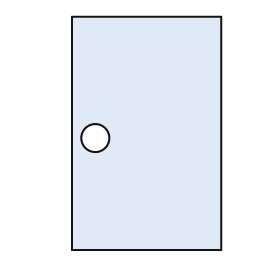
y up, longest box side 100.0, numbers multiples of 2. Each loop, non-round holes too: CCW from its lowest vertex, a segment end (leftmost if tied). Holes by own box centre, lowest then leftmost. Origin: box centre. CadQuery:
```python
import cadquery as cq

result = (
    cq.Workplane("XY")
    .moveTo(-32.0, -50.0)
    .lineTo(32.0, -50.0)
    .lineTo(32.0, 50.0)
    .lineTo(-32.0, 50.0)
    .close()
    .moveTo(-22.0, -2.0)
    .circle(6.0)
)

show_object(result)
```